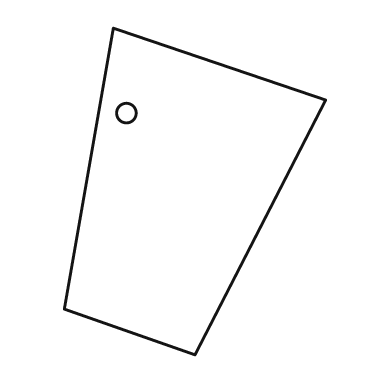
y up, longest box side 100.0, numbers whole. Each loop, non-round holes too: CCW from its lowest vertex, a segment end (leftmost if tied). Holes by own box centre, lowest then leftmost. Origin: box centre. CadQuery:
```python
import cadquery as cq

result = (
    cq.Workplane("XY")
    .moveTo(0.0, -50.0)
    .lineTo(40.0, 28.0)
    .lineTo(-25.0, 50.0)
    .lineTo(-40.0, -36.0)
    .close()
    .moveTo(-21.0, 24.0)
    .circle(3.0)
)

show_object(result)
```